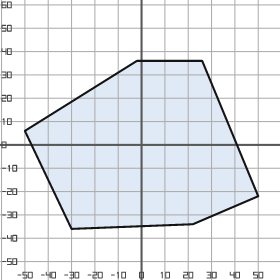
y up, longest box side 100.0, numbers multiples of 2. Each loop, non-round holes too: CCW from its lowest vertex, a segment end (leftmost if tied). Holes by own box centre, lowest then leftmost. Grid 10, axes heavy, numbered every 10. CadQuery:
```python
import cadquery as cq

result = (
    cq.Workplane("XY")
    .moveTo(-30.0, -36.0)
    .lineTo(22.0, -34.0)
    .lineTo(50.0, -22.0)
    .lineTo(26.0, 36.0)
    .lineTo(-2.0, 36.0)
    .lineTo(-50.0, 6.0)
    .close()
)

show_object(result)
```